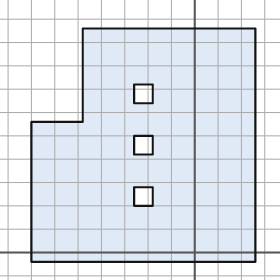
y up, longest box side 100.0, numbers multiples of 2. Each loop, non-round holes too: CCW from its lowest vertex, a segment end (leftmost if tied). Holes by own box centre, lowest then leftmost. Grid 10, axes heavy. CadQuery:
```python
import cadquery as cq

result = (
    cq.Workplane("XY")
    .moveTo(-70.0, -4.0)
    .lineTo(26.0, -4.0)
    .lineTo(26.0, 96.0)
    .lineTo(-48.0, 96.0)
    .lineTo(-48.0, 56.0)
    .lineTo(-70.0, 56.0)
    .close()
    .moveTo(-26.0, 20.0)
    .lineTo(-18.0, 20.0)
    .lineTo(-18.0, 28.0)
    .lineTo(-26.0, 28.0)
    .close()
    .moveTo(-26.0, 42.0)
    .lineTo(-18.0, 42.0)
    .lineTo(-18.0, 50.0)
    .lineTo(-26.0, 50.0)
    .close()
    .moveTo(-26.0, 64.0)
    .lineTo(-18.0, 64.0)
    .lineTo(-18.0, 72.0)
    .lineTo(-26.0, 72.0)
    .close()
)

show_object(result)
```